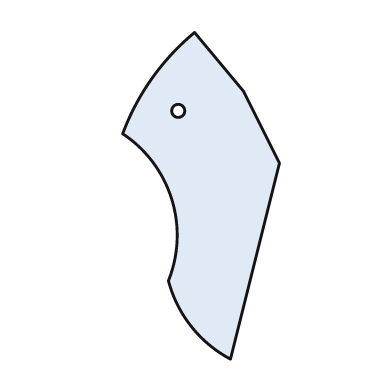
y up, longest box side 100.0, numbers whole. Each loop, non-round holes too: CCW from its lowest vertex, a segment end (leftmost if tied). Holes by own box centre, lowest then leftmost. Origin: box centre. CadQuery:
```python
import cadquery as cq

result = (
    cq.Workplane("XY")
    .moveTo(9.0, -50.0)
    .lineTo(24.0, 10.0)
    .lineTo(13.0, 32.0)
    .lineTo(-2.0, 50.0)
    .threePointArc((-15.0, 36.0), (-24.0, 19.0))
    .threePointArc((-9.0, -1.0), (-10.0, -26.0))
    .threePointArc((-3.0, -40.0), (9.0, -50.0))
    .close()
    .moveTo(-7.0, 26.0)
    .circle(2.0)
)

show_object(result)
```